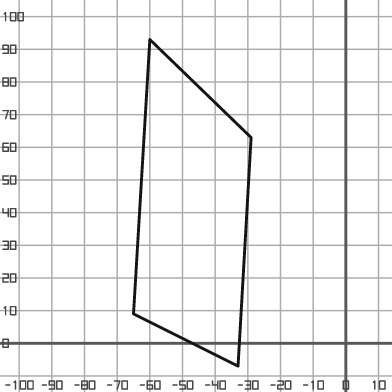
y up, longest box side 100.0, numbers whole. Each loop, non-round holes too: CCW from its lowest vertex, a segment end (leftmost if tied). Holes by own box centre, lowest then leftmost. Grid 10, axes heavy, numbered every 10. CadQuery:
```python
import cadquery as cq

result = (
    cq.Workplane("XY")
    .moveTo(-33.0, -7.0)
    .lineTo(-29.0, 63.0)
    .lineTo(-60.0, 93.0)
    .lineTo(-65.0, 9.0)
    .close()
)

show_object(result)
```